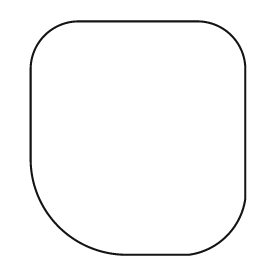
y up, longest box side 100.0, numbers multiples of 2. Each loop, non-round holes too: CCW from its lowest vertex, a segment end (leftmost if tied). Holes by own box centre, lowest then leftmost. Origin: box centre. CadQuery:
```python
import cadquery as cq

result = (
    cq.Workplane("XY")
    .moveTo(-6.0, -50.0)
    .lineTo(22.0, -50.0)
    .threePointArc((38.0, -42.0), (46.0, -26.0))
    .lineTo(46.0, 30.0)
    .threePointArc((40.0, 44.0), (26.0, 50.0))
    .lineTo(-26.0, 50.0)
    .threePointArc((-40.0, 44.0), (-46.0, 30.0))
    .lineTo(-46.0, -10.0)
    .threePointArc((-34.0, -38.0), (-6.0, -50.0))
    .close()
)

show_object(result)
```